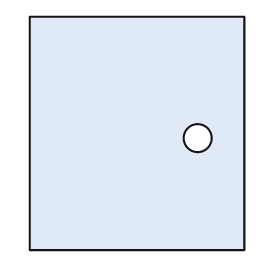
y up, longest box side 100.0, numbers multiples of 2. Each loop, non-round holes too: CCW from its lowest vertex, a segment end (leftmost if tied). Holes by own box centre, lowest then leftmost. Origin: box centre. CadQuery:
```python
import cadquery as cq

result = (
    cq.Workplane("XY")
    .moveTo(-46.0, -50.0)
    .lineTo(46.0, -50.0)
    .lineTo(46.0, 50.0)
    .lineTo(-46.0, 50.0)
    .close()
    .moveTo(26.0, -2.0)
    .circle(6.0)
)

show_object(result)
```